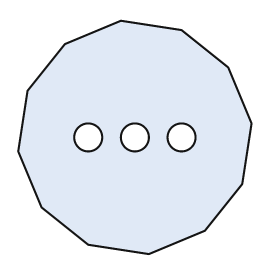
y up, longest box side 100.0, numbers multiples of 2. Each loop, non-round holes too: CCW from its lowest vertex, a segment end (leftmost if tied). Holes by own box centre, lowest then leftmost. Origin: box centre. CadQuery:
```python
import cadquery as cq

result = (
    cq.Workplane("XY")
    .moveTo(6.0, -50.0)
    .lineTo(30.0, -40.0)
    .lineTo(46.0, -20.0)
    .lineTo(50.0, 6.0)
    .lineTo(40.0, 30.0)
    .lineTo(20.0, 46.0)
    .lineTo(-6.0, 50.0)
    .lineTo(-30.0, 40.0)
    .lineTo(-46.0, 20.0)
    .lineTo(-50.0, -6.0)
    .lineTo(-40.0, -30.0)
    .lineTo(-20.0, -46.0)
    .close()
    .moveTo(-20.0, 0.0)
    .circle(6.0)
    .moveTo(0.0, 0.0)
    .circle(6.0)
    .moveTo(20.0, 0.0)
    .circle(6.0)
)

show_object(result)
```